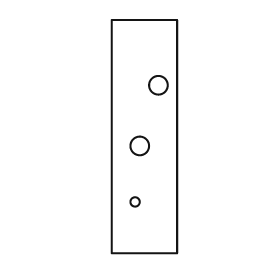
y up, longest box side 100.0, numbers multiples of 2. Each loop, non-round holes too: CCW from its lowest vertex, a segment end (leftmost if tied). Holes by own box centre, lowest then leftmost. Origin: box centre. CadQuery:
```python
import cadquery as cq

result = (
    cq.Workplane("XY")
    .moveTo(-14.0, -50.0)
    .lineTo(14.0, -50.0)
    .lineTo(14.0, 50.0)
    .lineTo(-14.0, 50.0)
    .close()
    .moveTo(-4.0, -28.0)
    .circle(2.0)
    .moveTo(-2.0, -4.0)
    .circle(4.0)
    .moveTo(6.0, 22.0)
    .circle(4.0)
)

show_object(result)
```